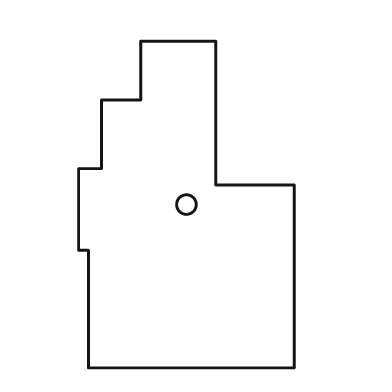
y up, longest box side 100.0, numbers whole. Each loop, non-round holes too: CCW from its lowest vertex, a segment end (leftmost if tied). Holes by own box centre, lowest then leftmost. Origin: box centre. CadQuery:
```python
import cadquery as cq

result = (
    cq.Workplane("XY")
    .moveTo(-30.0, -50.0)
    .lineTo(33.0, -50.0)
    .lineTo(33.0, 6.0)
    .lineTo(9.0, 6.0)
    .lineTo(9.0, 50.0)
    .lineTo(-14.0, 50.0)
    .lineTo(-14.0, 32.0)
    .lineTo(-26.0, 32.0)
    .lineTo(-26.0, 11.0)
    .lineTo(-33.0, 11.0)
    .lineTo(-33.0, -14.0)
    .lineTo(-30.0, -14.0)
    .close()
    .moveTo(0.0, 0.0)
    .circle(3.0)
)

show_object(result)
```